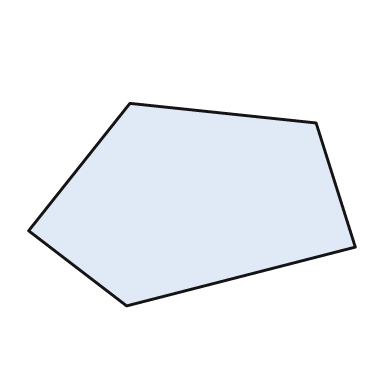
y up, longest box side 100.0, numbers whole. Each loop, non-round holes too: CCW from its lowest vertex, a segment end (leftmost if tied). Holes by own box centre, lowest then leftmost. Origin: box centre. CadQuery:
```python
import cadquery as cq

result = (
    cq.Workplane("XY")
    .moveTo(-20.0, -31.0)
    .lineTo(50.0, -13.0)
    .lineTo(38.0, 25.0)
    .lineTo(-19.0, 31.0)
    .lineTo(-50.0, -8.0)
    .close()
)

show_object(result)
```